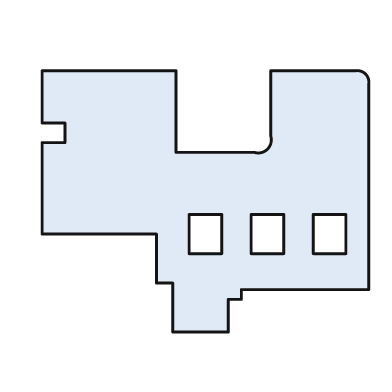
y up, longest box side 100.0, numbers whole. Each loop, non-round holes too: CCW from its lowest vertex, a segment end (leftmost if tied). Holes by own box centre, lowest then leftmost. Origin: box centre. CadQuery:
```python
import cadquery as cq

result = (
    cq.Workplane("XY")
    .moveTo(-10.0, -40.0)
    .lineTo(7.0, -40.0)
    .lineTo(7.0, -30.0)
    .lineTo(11.0, -30.0)
    .lineTo(11.0, -27.0)
    .lineTo(50.0, -27.0)
    .lineTo(50.0, 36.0)
    .threePointArc((49.0, 39.0), (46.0, 40.0))
    .lineTo(20.0, 40.0)
    .lineTo(20.0, 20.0)
    .threePointArc((19.0, 16.0), (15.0, 15.0))
    .lineTo(-9.0, 15.0)
    .lineTo(-9.0, 40.0)
    .lineTo(-50.0, 40.0)
    .lineTo(-50.0, 24.0)
    .lineTo(-43.0, 24.0)
    .lineTo(-43.0, 18.0)
    .lineTo(-50.0, 18.0)
    .lineTo(-50.0, -10.0)
    .lineTo(-15.0, -10.0)
    .lineTo(-15.0, -25.0)
    .lineTo(-10.0, -25.0)
    .close()
    .moveTo(-5.0, -16.0)
    .lineTo(5.0, -16.0)
    .lineTo(5.0, -4.0)
    .lineTo(-5.0, -4.0)
    .close()
    .moveTo(14.0, -16.0)
    .lineTo(24.0, -16.0)
    .lineTo(24.0, -4.0)
    .lineTo(14.0, -4.0)
    .close()
    .moveTo(33.0, -16.0)
    .lineTo(43.0, -16.0)
    .lineTo(43.0, -4.0)
    .lineTo(33.0, -4.0)
    .close()
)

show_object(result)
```